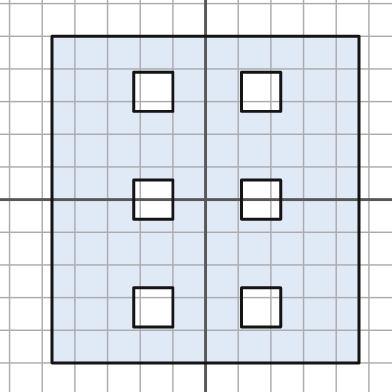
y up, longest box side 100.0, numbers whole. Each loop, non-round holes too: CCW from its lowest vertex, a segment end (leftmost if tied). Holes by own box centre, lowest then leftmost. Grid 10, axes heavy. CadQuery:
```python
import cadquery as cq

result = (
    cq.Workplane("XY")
    .moveTo(-47.0, -50.0)
    .lineTo(47.0, -50.0)
    .lineTo(47.0, 50.0)
    .lineTo(-47.0, 50.0)
    .close()
    .moveTo(-22.0, -39.0)
    .lineTo(-10.0, -39.0)
    .lineTo(-10.0, -27.0)
    .lineTo(-22.0, -27.0)
    .close()
    .moveTo(11.0, -39.0)
    .lineTo(23.0, -39.0)
    .lineTo(23.0, -27.0)
    .lineTo(11.0, -27.0)
    .close()
    .moveTo(-22.0, -6.0)
    .lineTo(-10.0, -6.0)
    .lineTo(-10.0, 6.0)
    .lineTo(-22.0, 6.0)
    .close()
    .moveTo(11.0, -6.0)
    .lineTo(23.0, -6.0)
    .lineTo(23.0, 6.0)
    .lineTo(11.0, 6.0)
    .close()
    .moveTo(-22.0, 27.0)
    .lineTo(-10.0, 27.0)
    .lineTo(-10.0, 39.0)
    .lineTo(-22.0, 39.0)
    .close()
    .moveTo(11.0, 27.0)
    .lineTo(23.0, 27.0)
    .lineTo(23.0, 39.0)
    .lineTo(11.0, 39.0)
    .close()
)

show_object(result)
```